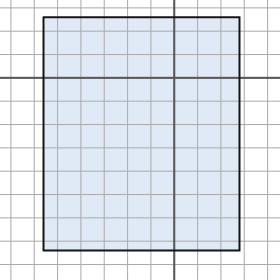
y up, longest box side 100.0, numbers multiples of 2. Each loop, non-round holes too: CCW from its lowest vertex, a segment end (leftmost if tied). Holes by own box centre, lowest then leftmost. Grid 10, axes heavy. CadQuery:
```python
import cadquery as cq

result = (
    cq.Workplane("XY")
    .moveTo(-56.0, -74.0)
    .lineTo(28.0, -74.0)
    .lineTo(28.0, 26.0)
    .lineTo(-56.0, 26.0)
    .close()
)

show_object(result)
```